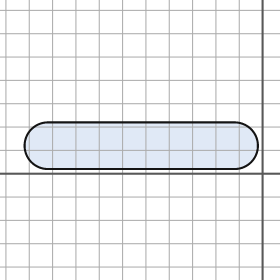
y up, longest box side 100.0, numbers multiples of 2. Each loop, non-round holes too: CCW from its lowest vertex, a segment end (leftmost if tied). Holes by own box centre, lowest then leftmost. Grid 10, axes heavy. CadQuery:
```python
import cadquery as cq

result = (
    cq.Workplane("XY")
    .moveTo(-92.0, 2.0)
    .lineTo(-12.0, 2.0)
    .threePointArc((-2.0, 12.0), (-12.0, 22.0))
    .lineTo(-92.0, 22.0)
    .threePointArc((-102.0, 12.0), (-92.0, 2.0))
    .close()
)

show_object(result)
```